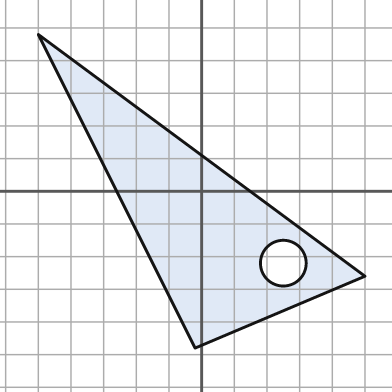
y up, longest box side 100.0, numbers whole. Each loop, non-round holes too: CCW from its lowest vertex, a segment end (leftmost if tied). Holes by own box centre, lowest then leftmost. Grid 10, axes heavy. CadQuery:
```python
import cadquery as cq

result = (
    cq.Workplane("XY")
    .moveTo(-2.0, -48.0)
    .lineTo(50.0, -26.0)
    .lineTo(-50.0, 48.0)
    .close()
    .moveTo(25.0, -22.0)
    .circle(7.0)
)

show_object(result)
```